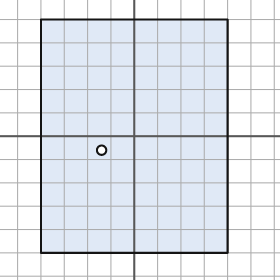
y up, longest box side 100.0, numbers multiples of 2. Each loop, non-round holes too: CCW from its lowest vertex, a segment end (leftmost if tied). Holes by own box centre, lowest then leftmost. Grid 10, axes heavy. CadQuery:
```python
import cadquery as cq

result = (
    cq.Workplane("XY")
    .moveTo(-40.0, -50.0)
    .lineTo(40.0, -50.0)
    .lineTo(40.0, 50.0)
    .lineTo(-40.0, 50.0)
    .close()
    .moveTo(-14.0, -6.0)
    .circle(2.0)
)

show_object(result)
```